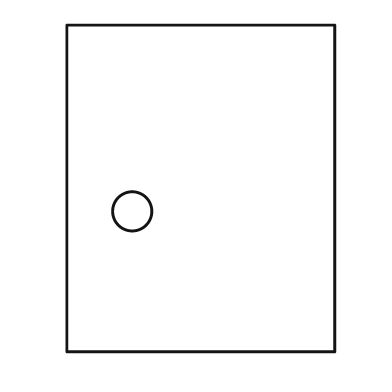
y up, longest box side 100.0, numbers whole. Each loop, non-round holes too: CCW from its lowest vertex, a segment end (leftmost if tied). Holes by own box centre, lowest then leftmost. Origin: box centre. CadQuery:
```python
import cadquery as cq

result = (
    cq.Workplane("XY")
    .moveTo(-41.0, -50.0)
    .lineTo(41.0, -50.0)
    .lineTo(41.0, 50.0)
    .lineTo(-41.0, 50.0)
    .close()
    .moveTo(-21.0, -7.0)
    .circle(6.0)
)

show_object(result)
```